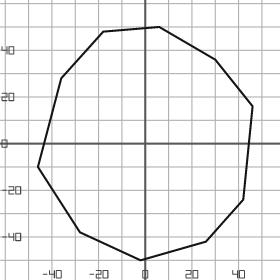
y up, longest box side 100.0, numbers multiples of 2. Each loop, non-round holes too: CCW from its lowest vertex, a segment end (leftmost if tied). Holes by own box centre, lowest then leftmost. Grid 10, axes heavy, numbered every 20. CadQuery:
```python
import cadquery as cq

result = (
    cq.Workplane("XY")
    .moveTo(-2.0, -50.0)
    .lineTo(26.0, -42.0)
    .lineTo(42.0, -24.0)
    .lineTo(46.0, 16.0)
    .lineTo(30.0, 36.0)
    .lineTo(6.0, 50.0)
    .lineTo(-18.0, 48.0)
    .lineTo(-36.0, 28.0)
    .lineTo(-46.0, -10.0)
    .lineTo(-28.0, -38.0)
    .close()
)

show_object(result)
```